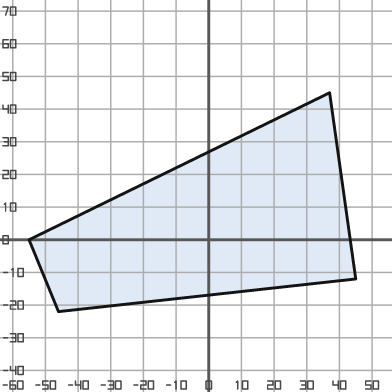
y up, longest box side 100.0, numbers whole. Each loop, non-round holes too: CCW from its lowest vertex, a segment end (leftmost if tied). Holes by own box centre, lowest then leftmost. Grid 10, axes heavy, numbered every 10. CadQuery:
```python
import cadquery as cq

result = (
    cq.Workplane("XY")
    .moveTo(-46.0, -22.0)
    .lineTo(45.0, -12.0)
    .lineTo(37.0, 45.0)
    .lineTo(-55.0, 0.0)
    .close()
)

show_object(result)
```